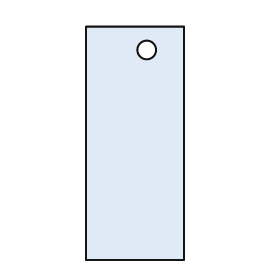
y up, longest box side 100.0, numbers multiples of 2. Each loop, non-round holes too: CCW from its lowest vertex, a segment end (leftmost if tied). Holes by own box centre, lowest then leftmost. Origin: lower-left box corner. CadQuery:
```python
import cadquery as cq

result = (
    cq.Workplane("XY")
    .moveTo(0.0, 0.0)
    .lineTo(42.0, 0.0)
    .lineTo(42.0, 100.0)
    .lineTo(0.0, 100.0)
    .close()
    .moveTo(26.0, 90.0)
    .circle(4.0)
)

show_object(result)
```